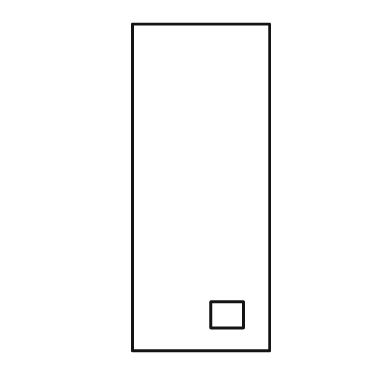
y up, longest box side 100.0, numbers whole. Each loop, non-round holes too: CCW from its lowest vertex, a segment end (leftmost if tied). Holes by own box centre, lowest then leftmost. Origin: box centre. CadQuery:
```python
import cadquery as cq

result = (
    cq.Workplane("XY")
    .moveTo(-21.0, -50.0)
    .lineTo(21.0, -50.0)
    .lineTo(21.0, 50.0)
    .lineTo(-21.0, 50.0)
    .close()
    .moveTo(3.0, -43.0)
    .lineTo(13.0, -43.0)
    .lineTo(13.0, -35.0)
    .lineTo(3.0, -35.0)
    .close()
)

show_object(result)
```